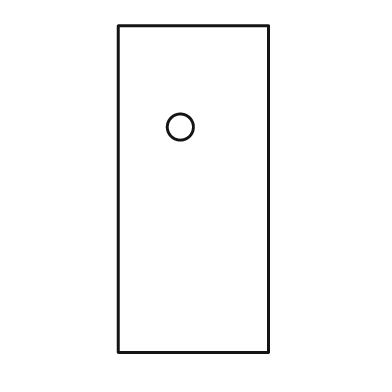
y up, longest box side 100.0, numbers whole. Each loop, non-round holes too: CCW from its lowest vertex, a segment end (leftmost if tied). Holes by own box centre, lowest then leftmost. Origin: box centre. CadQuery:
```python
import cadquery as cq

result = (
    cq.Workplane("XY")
    .moveTo(-23.0, -50.0)
    .lineTo(23.0, -50.0)
    .lineTo(23.0, 50.0)
    .lineTo(-23.0, 50.0)
    .close()
    .moveTo(-4.0, 19.0)
    .circle(4.0)
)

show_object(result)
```